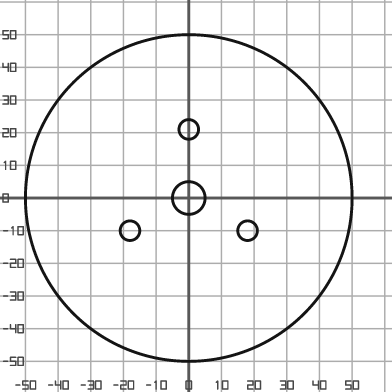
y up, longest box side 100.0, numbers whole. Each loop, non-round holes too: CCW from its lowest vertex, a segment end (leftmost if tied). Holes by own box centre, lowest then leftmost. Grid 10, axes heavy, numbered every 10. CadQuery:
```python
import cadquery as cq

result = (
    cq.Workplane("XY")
    .moveTo(0.0, 0.0)
    .circle(50.0)
    .moveTo(-18.0, -10.0)
    .circle(3.0)
    .moveTo(18.0, -10.0)
    .circle(3.0)
    .moveTo(0.0, 0.0)
    .circle(5.0)
    .moveTo(0.0, 21.0)
    .circle(3.0)
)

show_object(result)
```